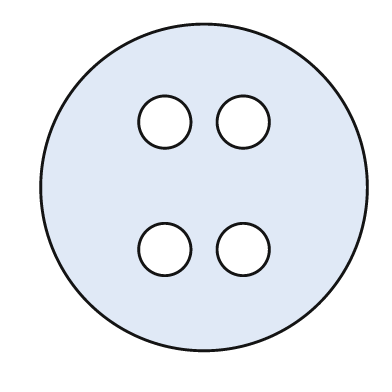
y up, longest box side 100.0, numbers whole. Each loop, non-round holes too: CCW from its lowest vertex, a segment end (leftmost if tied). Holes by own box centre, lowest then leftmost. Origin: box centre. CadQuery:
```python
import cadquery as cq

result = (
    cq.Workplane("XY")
    .moveTo(0.0, 0.0)
    .circle(50.0)
    .moveTo(-12.0, -19.0)
    .circle(8.0)
    .moveTo(12.0, -19.0)
    .circle(8.0)
    .moveTo(-12.0, 20.0)
    .circle(8.0)
    .moveTo(12.0, 20.0)
    .circle(8.0)
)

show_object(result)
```